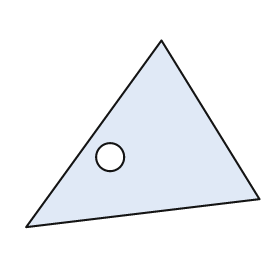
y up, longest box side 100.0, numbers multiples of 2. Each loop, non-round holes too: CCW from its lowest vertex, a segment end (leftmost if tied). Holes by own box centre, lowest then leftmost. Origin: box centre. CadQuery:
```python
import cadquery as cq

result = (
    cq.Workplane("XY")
    .moveTo(-50.0, -40.0)
    .lineTo(50.0, -28.0)
    .lineTo(8.0, 40.0)
    .close()
    .moveTo(-14.0, -10.0)
    .circle(6.0)
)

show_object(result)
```